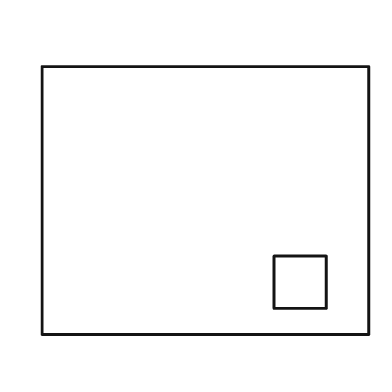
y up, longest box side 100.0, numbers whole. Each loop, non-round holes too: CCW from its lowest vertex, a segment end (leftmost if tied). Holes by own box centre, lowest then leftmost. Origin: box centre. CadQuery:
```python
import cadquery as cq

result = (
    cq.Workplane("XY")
    .moveTo(-50.0, -41.0)
    .lineTo(50.0, -41.0)
    .lineTo(50.0, 41.0)
    .lineTo(-50.0, 41.0)
    .close()
    .moveTo(21.0, -33.0)
    .lineTo(37.0, -33.0)
    .lineTo(37.0, -17.0)
    .lineTo(21.0, -17.0)
    .close()
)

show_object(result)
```